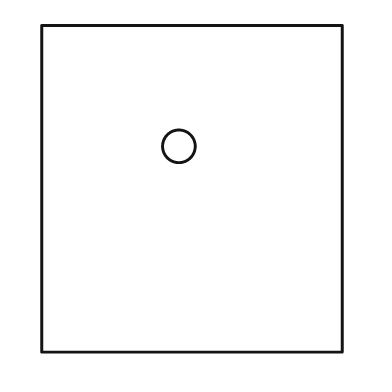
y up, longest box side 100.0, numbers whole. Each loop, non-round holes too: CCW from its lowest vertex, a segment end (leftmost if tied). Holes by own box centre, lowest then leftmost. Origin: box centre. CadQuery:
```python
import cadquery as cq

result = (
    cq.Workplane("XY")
    .moveTo(-46.0, -50.0)
    .lineTo(46.0, -50.0)
    .lineTo(46.0, 50.0)
    .lineTo(-46.0, 50.0)
    .close()
    .moveTo(-4.0, 13.0)
    .circle(5.0)
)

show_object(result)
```